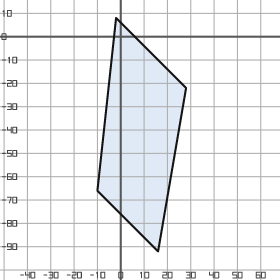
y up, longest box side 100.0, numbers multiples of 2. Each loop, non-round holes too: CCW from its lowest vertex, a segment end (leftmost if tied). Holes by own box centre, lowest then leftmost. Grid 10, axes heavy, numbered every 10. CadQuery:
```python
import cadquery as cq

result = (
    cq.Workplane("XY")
    .moveTo(16.0, -92.0)
    .lineTo(28.0, -22.0)
    .lineTo(-2.0, 8.0)
    .lineTo(-10.0, -66.0)
    .close()
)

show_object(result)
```